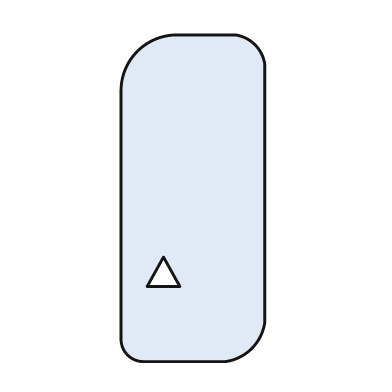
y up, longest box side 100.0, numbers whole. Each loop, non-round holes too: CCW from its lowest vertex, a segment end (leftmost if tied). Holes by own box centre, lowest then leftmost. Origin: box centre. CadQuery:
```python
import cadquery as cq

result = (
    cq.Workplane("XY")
    .moveTo(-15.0, -50.0)
    .lineTo(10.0, -50.0)
    .threePointArc((18.0, -46.0), (22.0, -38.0))
    .lineTo(22.0, 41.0)
    .threePointArc((19.0, 47.0), (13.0, 50.0))
    .lineTo(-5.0, 50.0)
    .threePointArc((-17.0, 45.0), (-22.0, 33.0))
    .lineTo(-22.0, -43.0)
    .threePointArc((-20.0, -48.0), (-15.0, -50.0))
    .close()
    .moveTo(-14.0, -27.0)
    .lineTo(-4.0, -27.0)
    .lineTo(-9.0, -18.0)
    .close()
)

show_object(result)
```